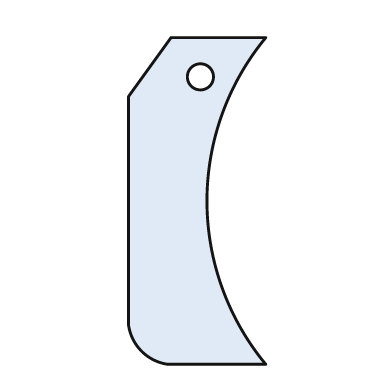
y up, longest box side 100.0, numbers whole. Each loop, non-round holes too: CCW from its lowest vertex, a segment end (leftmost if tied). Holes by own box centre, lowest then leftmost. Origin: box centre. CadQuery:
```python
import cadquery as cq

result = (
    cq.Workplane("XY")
    .moveTo(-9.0, -50.0)
    .lineTo(21.0, -50.0)
    .threePointArc((3.0, 0.0), (21.0, 50.0))
    .lineTo(-8.0, 50.0)
    .lineTo(-21.0, 32.0)
    .lineTo(-21.0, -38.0)
    .threePointArc((-17.0, -46.0), (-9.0, -50.0))
    .close()
    .moveTo(1.0, 38.0)
    .circle(4.0)
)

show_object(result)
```